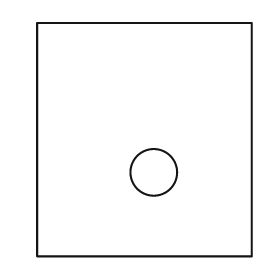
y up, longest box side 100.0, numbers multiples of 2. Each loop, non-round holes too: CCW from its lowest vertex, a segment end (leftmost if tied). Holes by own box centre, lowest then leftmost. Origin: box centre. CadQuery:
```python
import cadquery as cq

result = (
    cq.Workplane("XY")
    .moveTo(-46.0, -50.0)
    .lineTo(46.0, -50.0)
    .lineTo(46.0, 50.0)
    .lineTo(-46.0, 50.0)
    .close()
    .moveTo(4.0, -14.0)
    .circle(10.0)
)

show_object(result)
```